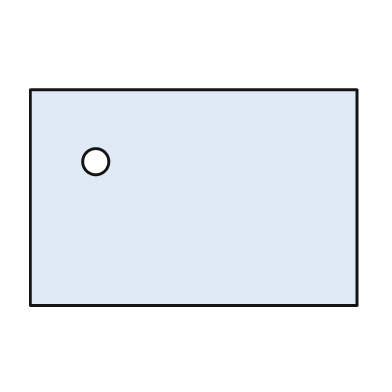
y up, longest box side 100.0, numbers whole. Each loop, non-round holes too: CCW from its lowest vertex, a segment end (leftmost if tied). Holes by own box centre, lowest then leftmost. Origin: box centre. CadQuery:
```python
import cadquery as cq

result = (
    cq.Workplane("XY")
    .moveTo(-50.0, -33.0)
    .lineTo(50.0, -33.0)
    .lineTo(50.0, 33.0)
    .lineTo(-50.0, 33.0)
    .close()
    .moveTo(-30.0, 11.0)
    .circle(4.0)
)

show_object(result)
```